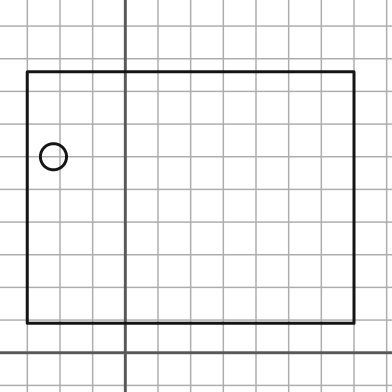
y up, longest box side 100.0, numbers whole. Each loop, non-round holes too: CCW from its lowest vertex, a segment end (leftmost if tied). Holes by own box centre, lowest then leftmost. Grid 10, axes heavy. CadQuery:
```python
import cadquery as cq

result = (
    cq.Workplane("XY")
    .moveTo(-30.0, 9.0)
    .lineTo(70.0, 9.0)
    .lineTo(70.0, 86.0)
    .lineTo(-30.0, 86.0)
    .close()
    .moveTo(-22.0, 60.0)
    .circle(4.0)
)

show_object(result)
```